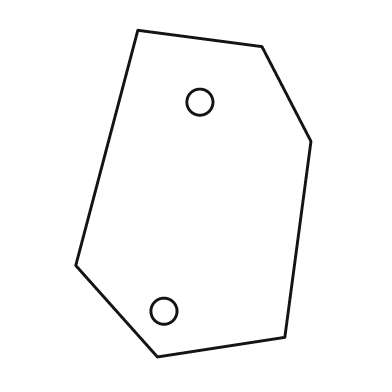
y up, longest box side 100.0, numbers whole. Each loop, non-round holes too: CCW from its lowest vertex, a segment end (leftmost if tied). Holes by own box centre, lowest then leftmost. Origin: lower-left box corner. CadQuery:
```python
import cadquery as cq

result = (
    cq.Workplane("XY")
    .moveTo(25.0, 0.0)
    .lineTo(64.0, 6.0)
    .lineTo(72.0, 66.0)
    .lineTo(57.0, 95.0)
    .lineTo(19.0, 100.0)
    .lineTo(0.0, 28.0)
    .close()
    .moveTo(27.0, 14.0)
    .circle(4.0)
    .moveTo(38.0, 78.0)
    .circle(4.0)
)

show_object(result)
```